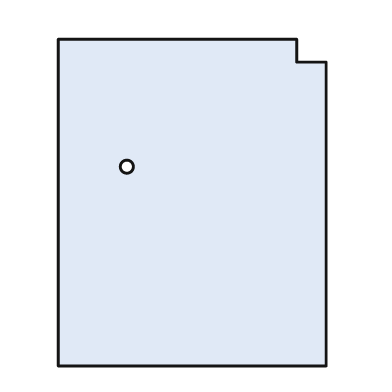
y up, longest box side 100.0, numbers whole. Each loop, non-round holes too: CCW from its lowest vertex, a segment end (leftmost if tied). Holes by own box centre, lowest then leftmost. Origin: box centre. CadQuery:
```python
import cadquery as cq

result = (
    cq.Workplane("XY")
    .moveTo(-41.0, -50.0)
    .lineTo(41.0, -50.0)
    .lineTo(41.0, 43.0)
    .lineTo(32.0, 43.0)
    .lineTo(32.0, 50.0)
    .lineTo(-41.0, 50.0)
    .close()
    .moveTo(-20.0, 11.0)
    .circle(2.0)
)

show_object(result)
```